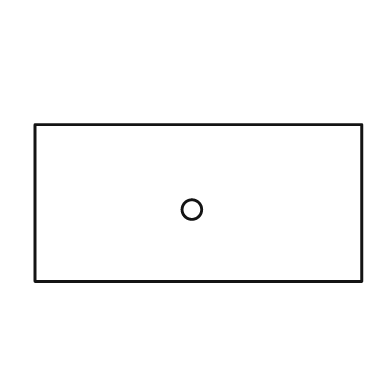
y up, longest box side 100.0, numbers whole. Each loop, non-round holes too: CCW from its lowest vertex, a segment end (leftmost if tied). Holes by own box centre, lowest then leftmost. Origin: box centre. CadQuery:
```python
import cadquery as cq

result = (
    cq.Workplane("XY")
    .moveTo(-50.0, -24.0)
    .lineTo(50.0, -24.0)
    .lineTo(50.0, 24.0)
    .lineTo(-50.0, 24.0)
    .close()
    .moveTo(-2.0, -2.0)
    .circle(3.0)
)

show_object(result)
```